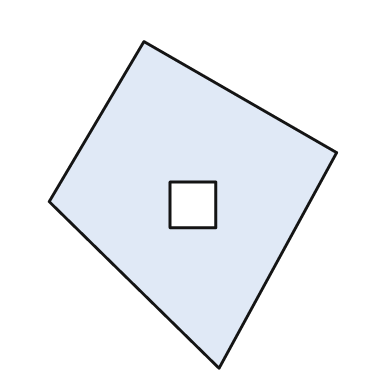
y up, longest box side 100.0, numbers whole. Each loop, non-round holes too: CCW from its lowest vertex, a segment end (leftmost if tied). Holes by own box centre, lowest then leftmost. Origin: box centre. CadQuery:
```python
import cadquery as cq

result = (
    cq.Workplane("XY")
    .moveTo(8.0, -50.0)
    .lineTo(44.0, 16.0)
    .lineTo(-15.0, 50.0)
    .lineTo(-44.0, 1.0)
    .close()
    .moveTo(-7.0, -7.0)
    .lineTo(7.0, -7.0)
    .lineTo(7.0, 7.0)
    .lineTo(-7.0, 7.0)
    .close()
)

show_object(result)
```